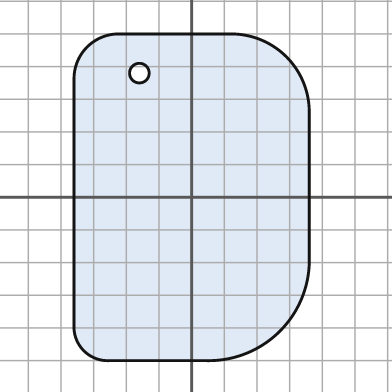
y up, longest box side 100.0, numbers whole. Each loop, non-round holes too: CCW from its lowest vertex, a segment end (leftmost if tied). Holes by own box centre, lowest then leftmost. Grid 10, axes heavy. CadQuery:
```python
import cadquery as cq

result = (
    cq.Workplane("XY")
    .moveTo(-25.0, -50.0)
    .lineTo(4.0, -50.0)
    .threePointArc((27.0, -41.0), (36.0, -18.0))
    .lineTo(36.0, 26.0)
    .threePointArc((29.0, 43.0), (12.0, 50.0))
    .lineTo(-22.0, 50.0)
    .threePointArc((-32.0, 46.0), (-36.0, 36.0))
    .lineTo(-36.0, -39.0)
    .threePointArc((-33.0, -47.0), (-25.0, -50.0))
    .close()
    .moveTo(-16.0, 38.0)
    .circle(3.0)
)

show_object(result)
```